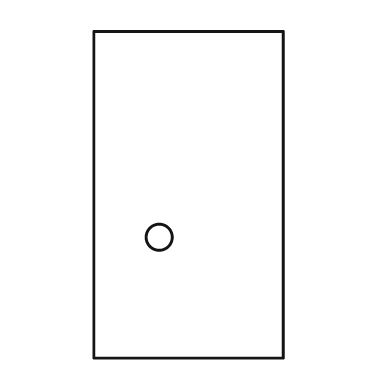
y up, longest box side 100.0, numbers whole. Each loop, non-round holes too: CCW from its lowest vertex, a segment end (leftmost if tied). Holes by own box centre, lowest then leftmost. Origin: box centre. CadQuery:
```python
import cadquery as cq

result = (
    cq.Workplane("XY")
    .moveTo(-29.0, -50.0)
    .lineTo(29.0, -50.0)
    .lineTo(29.0, 50.0)
    .lineTo(-29.0, 50.0)
    .close()
    .moveTo(-9.0, -13.0)
    .circle(4.0)
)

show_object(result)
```